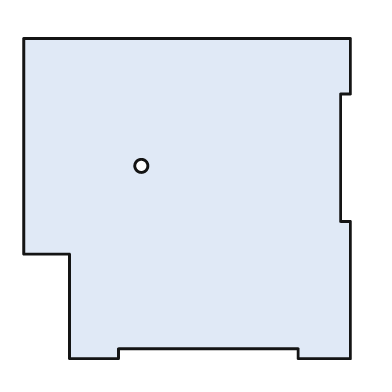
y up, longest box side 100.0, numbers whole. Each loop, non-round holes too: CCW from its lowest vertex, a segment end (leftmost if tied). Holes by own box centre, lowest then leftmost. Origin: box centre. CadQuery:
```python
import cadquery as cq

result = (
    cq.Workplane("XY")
    .moveTo(-36.0, -49.0)
    .lineTo(-21.0, -49.0)
    .lineTo(-21.0, -46.0)
    .lineTo(34.0, -46.0)
    .lineTo(34.0, -49.0)
    .lineTo(50.0, -49.0)
    .lineTo(50.0, -7.0)
    .lineTo(47.0, -7.0)
    .lineTo(47.0, 32.0)
    .lineTo(50.0, 32.0)
    .lineTo(50.0, 49.0)
    .lineTo(-50.0, 49.0)
    .lineTo(-50.0, -17.0)
    .lineTo(-36.0, -17.0)
    .close()
    .moveTo(-14.0, 10.0)
    .circle(2.0)
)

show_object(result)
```